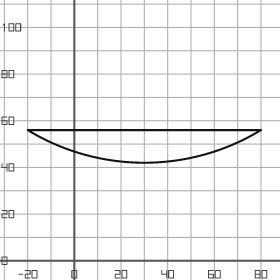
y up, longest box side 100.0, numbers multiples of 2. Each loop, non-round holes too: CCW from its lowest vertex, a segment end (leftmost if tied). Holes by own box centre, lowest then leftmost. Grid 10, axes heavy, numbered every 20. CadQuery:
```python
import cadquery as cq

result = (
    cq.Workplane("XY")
    .moveTo(-20.0, 56.0)
    .threePointArc((30.0, 42.0), (80.0, 56.0))
    .close()
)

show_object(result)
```